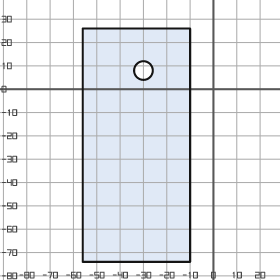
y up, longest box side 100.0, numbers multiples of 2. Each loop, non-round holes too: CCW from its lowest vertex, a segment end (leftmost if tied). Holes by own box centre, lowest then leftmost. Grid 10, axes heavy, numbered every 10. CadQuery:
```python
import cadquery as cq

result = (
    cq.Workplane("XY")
    .moveTo(-56.0, -74.0)
    .lineTo(-10.0, -74.0)
    .lineTo(-10.0, 26.0)
    .lineTo(-56.0, 26.0)
    .close()
    .moveTo(-30.0, 8.0)
    .circle(4.0)
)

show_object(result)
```